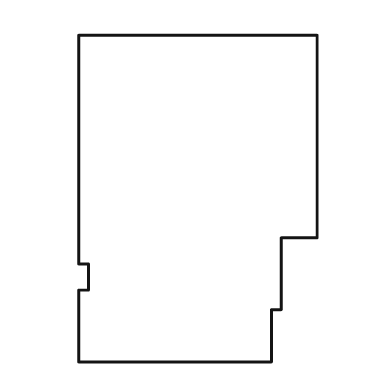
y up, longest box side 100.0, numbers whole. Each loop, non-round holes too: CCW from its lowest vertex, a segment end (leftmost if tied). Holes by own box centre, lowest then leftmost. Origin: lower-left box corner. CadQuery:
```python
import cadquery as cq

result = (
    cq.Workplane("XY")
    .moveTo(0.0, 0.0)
    .lineTo(59.0, 0.0)
    .lineTo(59.0, 16.0)
    .lineTo(62.0, 16.0)
    .lineTo(62.0, 38.0)
    .lineTo(73.0, 38.0)
    .lineTo(73.0, 100.0)
    .lineTo(0.0, 100.0)
    .lineTo(0.0, 30.0)
    .lineTo(3.0, 30.0)
    .lineTo(3.0, 22.0)
    .lineTo(0.0, 22.0)
    .close()
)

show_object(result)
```